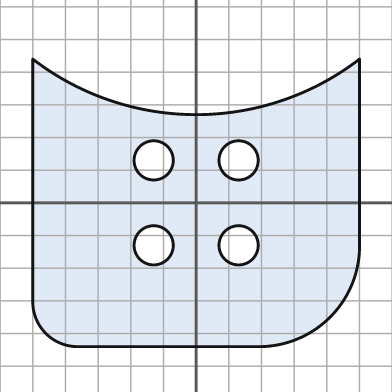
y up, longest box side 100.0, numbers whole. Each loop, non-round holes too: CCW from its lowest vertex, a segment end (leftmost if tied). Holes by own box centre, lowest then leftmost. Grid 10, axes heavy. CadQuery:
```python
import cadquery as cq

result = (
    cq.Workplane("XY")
    .moveTo(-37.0, -44.0)
    .lineTo(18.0, -44.0)
    .threePointArc((41.0, -35.0), (50.0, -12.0))
    .lineTo(50.0, 44.0)
    .threePointArc((0.0, 27.0), (-50.0, 44.0))
    .lineTo(-50.0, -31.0)
    .threePointArc((-46.0, -40.0), (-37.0, -44.0))
    .close()
    .moveTo(-13.0, -13.0)
    .circle(6.0)
    .moveTo(13.0, -13.0)
    .circle(6.0)
    .moveTo(-13.0, 13.0)
    .circle(6.0)
    .moveTo(13.0, 13.0)
    .circle(6.0)
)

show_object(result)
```